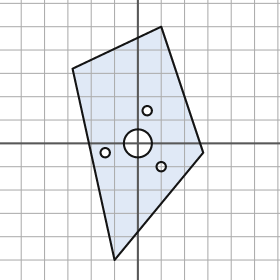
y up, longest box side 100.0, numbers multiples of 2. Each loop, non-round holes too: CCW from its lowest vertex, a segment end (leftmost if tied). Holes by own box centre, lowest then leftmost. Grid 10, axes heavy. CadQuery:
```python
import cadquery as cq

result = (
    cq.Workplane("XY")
    .moveTo(-10.0, -50.0)
    .lineTo(28.0, -4.0)
    .lineTo(10.0, 50.0)
    .lineTo(-28.0, 32.0)
    .close()
    .moveTo(10.0, -10.0)
    .circle(2.0)
    .moveTo(-14.0, -4.0)
    .circle(2.0)
    .moveTo(0.0, 0.0)
    .circle(6.0)
    .moveTo(4.0, 14.0)
    .circle(2.0)
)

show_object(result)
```